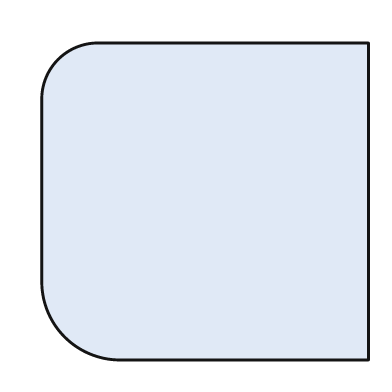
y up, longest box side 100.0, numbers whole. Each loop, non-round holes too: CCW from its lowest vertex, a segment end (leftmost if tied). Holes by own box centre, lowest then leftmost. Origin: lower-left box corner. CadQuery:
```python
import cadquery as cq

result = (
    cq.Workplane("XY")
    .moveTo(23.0, 0.0)
    .lineTo(100.0, 0.0)
    .lineTo(100.0, 97.0)
    .lineTo(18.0, 97.0)
    .threePointArc((5.0, 92.0), (0.0, 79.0))
    .lineTo(0.0, 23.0)
    .threePointArc((7.0, 7.0), (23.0, 0.0))
    .close()
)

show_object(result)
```